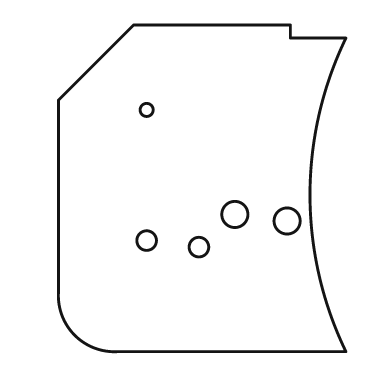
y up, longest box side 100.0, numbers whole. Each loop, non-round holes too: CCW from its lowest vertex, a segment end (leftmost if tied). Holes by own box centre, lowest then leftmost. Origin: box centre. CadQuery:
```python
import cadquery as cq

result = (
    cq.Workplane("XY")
    .moveTo(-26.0, -50.0)
    .lineTo(44.0, -50.0)
    .threePointArc((33.0, -2.0), (44.0, 46.0))
    .lineTo(27.0, 46.0)
    .lineTo(27.0, 50.0)
    .lineTo(-21.0, 50.0)
    .lineTo(-44.0, 27.0)
    .lineTo(-44.0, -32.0)
    .threePointArc((-39.0, -45.0), (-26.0, -50.0))
    .close()
    .moveTo(-1.0, -18.0)
    .circle(3.0)
    .moveTo(-17.0, -16.0)
    .circle(3.0)
    .moveTo(26.0, -10.0)
    .circle(4.0)
    .moveTo(10.0, -8.0)
    .circle(4.0)
    .moveTo(-17.0, 24.0)
    .circle(2.0)
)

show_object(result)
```